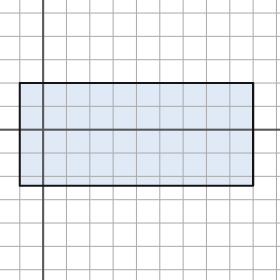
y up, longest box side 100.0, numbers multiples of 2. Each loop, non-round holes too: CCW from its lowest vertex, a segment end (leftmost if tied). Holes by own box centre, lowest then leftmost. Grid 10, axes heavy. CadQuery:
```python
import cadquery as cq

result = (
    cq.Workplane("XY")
    .moveTo(-10.0, -24.0)
    .lineTo(90.0, -24.0)
    .lineTo(90.0, 20.0)
    .lineTo(-10.0, 20.0)
    .close()
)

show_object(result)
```